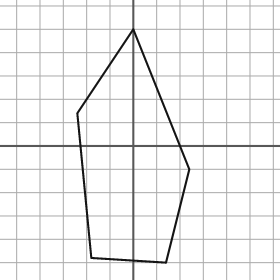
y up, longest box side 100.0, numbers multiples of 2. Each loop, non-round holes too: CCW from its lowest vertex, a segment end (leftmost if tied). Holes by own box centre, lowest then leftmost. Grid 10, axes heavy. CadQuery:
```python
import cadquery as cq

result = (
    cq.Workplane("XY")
    .moveTo(14.0, -50.0)
    .lineTo(24.0, -10.0)
    .lineTo(0.0, 50.0)
    .lineTo(-24.0, 14.0)
    .lineTo(-18.0, -48.0)
    .close()
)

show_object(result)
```